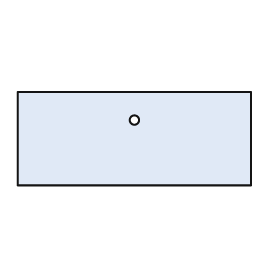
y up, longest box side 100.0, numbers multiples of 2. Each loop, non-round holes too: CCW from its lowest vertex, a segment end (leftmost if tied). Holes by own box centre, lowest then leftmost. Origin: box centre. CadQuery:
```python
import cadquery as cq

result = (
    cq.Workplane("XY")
    .moveTo(-50.0, -20.0)
    .lineTo(50.0, -20.0)
    .lineTo(50.0, 20.0)
    .lineTo(-50.0, 20.0)
    .close()
    .moveTo(0.0, 8.0)
    .circle(2.0)
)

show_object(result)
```